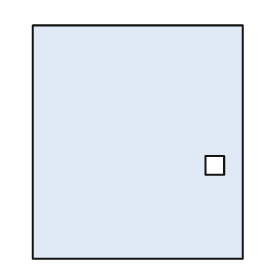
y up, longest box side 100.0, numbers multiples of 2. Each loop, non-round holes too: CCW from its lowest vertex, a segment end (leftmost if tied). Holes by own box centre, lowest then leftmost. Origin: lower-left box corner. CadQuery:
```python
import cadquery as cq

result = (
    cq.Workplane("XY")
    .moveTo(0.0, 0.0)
    .lineTo(90.0, 0.0)
    .lineTo(90.0, 100.0)
    .lineTo(0.0, 100.0)
    .close()
    .moveTo(74.0, 36.0)
    .lineTo(82.0, 36.0)
    .lineTo(82.0, 44.0)
    .lineTo(74.0, 44.0)
    .close()
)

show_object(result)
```